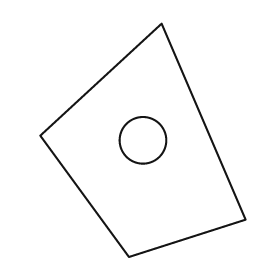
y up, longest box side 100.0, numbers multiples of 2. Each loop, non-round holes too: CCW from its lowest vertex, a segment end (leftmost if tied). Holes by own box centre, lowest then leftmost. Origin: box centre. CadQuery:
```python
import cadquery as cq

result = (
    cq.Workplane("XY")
    .moveTo(-6.0, -50.0)
    .lineTo(44.0, -34.0)
    .lineTo(8.0, 50.0)
    .lineTo(-44.0, 2.0)
    .close()
    .moveTo(0.0, 0.0)
    .circle(10.0)
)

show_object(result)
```